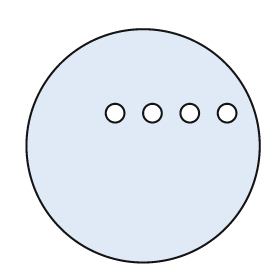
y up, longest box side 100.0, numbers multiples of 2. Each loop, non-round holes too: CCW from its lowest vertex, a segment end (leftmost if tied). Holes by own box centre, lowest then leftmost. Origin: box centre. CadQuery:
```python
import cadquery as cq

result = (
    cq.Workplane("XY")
    .moveTo(0.0, 0.0)
    .circle(50.0)
    .moveTo(-12.0, 14.0)
    .circle(4.0)
    .moveTo(4.0, 14.0)
    .circle(4.0)
    .moveTo(20.0, 14.0)
    .circle(4.0)
    .moveTo(36.0, 14.0)
    .circle(4.0)
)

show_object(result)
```